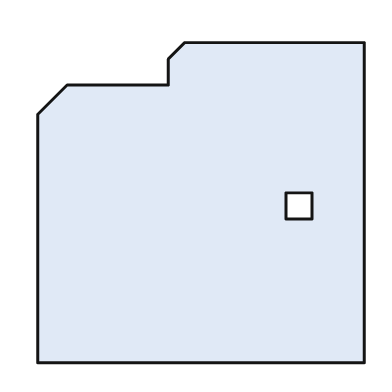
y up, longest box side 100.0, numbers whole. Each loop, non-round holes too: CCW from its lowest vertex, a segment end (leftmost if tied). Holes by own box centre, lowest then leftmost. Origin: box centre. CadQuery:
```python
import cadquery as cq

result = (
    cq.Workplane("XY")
    .moveTo(-50.0, -49.0)
    .lineTo(50.0, -49.0)
    .lineTo(50.0, 49.0)
    .lineTo(-5.0, 49.0)
    .lineTo(-10.0, 44.0)
    .lineTo(-10.0, 36.0)
    .lineTo(-41.0, 36.0)
    .lineTo(-50.0, 27.0)
    .close()
    .moveTo(26.0, -5.0)
    .lineTo(34.0, -5.0)
    .lineTo(34.0, 3.0)
    .lineTo(26.0, 3.0)
    .close()
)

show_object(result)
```